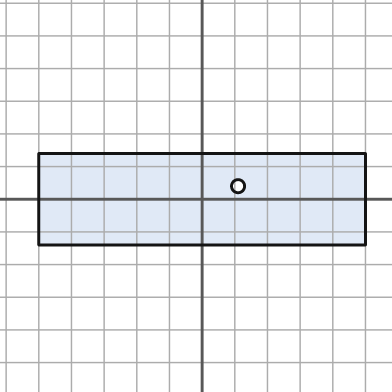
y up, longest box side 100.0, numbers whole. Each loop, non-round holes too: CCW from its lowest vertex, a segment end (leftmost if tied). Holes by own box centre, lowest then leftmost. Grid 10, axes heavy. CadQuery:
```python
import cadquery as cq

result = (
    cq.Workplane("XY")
    .moveTo(-50.0, -14.0)
    .lineTo(50.0, -14.0)
    .lineTo(50.0, 14.0)
    .lineTo(-50.0, 14.0)
    .close()
    .moveTo(11.0, 4.0)
    .circle(2.0)
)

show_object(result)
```